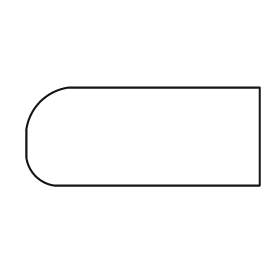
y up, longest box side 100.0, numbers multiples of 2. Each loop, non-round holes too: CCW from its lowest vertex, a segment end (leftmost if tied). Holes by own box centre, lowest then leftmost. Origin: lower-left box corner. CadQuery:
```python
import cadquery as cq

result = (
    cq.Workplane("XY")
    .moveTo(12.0, 0.0)
    .lineTo(100.0, 0.0)
    .lineTo(100.0, 42.0)
    .lineTo(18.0, 42.0)
    .threePointArc((6.0, 36.0), (0.0, 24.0))
    .lineTo(0.0, 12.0)
    .threePointArc((4.0, 4.0), (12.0, 0.0))
    .close()
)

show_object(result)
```